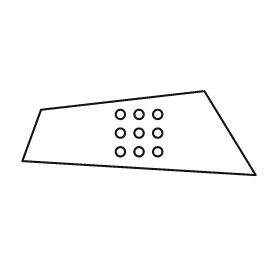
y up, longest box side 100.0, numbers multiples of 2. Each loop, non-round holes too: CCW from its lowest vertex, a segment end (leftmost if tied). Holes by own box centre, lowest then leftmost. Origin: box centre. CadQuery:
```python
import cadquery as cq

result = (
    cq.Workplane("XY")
    .moveTo(50.0, -18.0)
    .lineTo(28.0, 18.0)
    .lineTo(-42.0, 10.0)
    .lineTo(-50.0, -12.0)
    .close()
    .moveTo(-8.0, -8.0)
    .circle(2.0)
    .moveTo(0.0, -8.0)
    .circle(2.0)
    .moveTo(8.0, -8.0)
    .circle(2.0)
    .moveTo(-8.0, 0.0)
    .circle(2.0)
    .moveTo(0.0, 0.0)
    .circle(2.0)
    .moveTo(8.0, 0.0)
    .circle(2.0)
    .moveTo(-8.0, 8.0)
    .circle(2.0)
    .moveTo(0.0, 8.0)
    .circle(2.0)
    .moveTo(8.0, 8.0)
    .circle(2.0)
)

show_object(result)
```